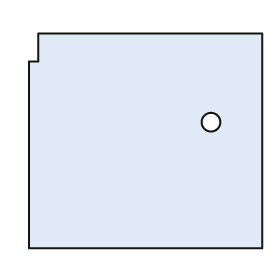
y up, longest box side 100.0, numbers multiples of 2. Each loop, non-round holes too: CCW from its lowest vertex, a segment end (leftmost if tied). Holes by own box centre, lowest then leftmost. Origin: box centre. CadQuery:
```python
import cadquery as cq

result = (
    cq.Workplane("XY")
    .moveTo(-50.0, -46.0)
    .lineTo(50.0, -46.0)
    .lineTo(50.0, 46.0)
    .lineTo(-46.0, 46.0)
    .lineTo(-46.0, 34.0)
    .lineTo(-50.0, 34.0)
    .close()
    .moveTo(28.0, 8.0)
    .circle(4.0)
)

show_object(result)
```